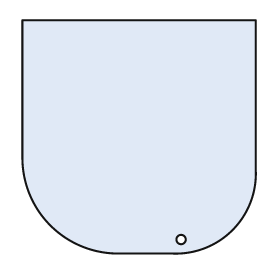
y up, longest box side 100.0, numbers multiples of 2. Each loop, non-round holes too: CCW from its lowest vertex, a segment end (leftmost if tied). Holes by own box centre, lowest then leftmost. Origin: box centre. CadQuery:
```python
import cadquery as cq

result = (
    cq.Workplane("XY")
    .moveTo(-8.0, -50.0)
    .lineTo(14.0, -50.0)
    .threePointArc((40.0, -40.0), (50.0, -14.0))
    .lineTo(50.0, 50.0)
    .lineTo(-50.0, 50.0)
    .lineTo(-50.0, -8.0)
    .threePointArc((-38.0, -38.0), (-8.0, -50.0))
    .close()
    .moveTo(18.0, -44.0)
    .circle(2.0)
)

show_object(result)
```